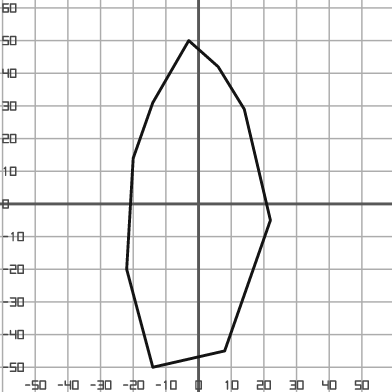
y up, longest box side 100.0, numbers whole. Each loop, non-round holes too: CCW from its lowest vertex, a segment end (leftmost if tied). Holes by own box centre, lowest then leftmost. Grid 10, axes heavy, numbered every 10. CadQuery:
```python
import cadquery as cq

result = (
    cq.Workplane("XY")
    .moveTo(-14.0, -50.0)
    .lineTo(8.0, -45.0)
    .lineTo(22.0, -5.0)
    .lineTo(14.0, 29.0)
    .lineTo(6.0, 42.0)
    .lineTo(-3.0, 50.0)
    .lineTo(-14.0, 31.0)
    .lineTo(-20.0, 14.0)
    .lineTo(-22.0, -20.0)
    .close()
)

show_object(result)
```